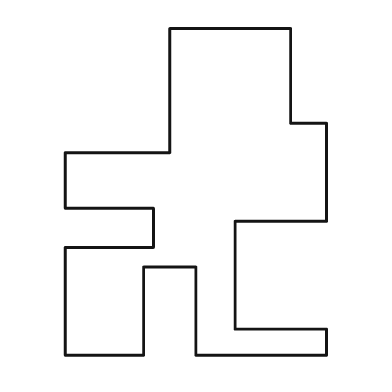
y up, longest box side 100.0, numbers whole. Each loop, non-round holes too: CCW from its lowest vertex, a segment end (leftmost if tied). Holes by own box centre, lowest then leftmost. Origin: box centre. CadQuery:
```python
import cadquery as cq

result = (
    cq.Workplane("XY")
    .moveTo(-40.0, -50.0)
    .lineTo(-16.0, -50.0)
    .lineTo(-16.0, -23.0)
    .lineTo(0.0, -23.0)
    .lineTo(0.0, -50.0)
    .lineTo(40.0, -50.0)
    .lineTo(40.0, -42.0)
    .lineTo(12.0, -42.0)
    .lineTo(12.0, -9.0)
    .lineTo(40.0, -9.0)
    .lineTo(40.0, 21.0)
    .lineTo(29.0, 21.0)
    .lineTo(29.0, 50.0)
    .lineTo(-8.0, 50.0)
    .lineTo(-8.0, 12.0)
    .lineTo(-40.0, 12.0)
    .lineTo(-40.0, -5.0)
    .lineTo(-13.0, -5.0)
    .lineTo(-13.0, -17.0)
    .lineTo(-40.0, -17.0)
    .close()
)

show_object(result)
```